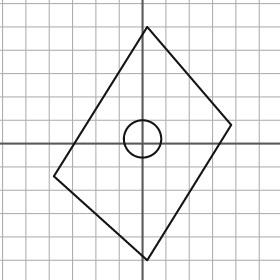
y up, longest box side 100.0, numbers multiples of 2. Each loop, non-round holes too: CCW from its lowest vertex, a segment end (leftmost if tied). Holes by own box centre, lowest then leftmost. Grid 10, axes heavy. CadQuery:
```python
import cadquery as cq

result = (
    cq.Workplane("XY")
    .moveTo(2.0, -50.0)
    .lineTo(38.0, 8.0)
    .lineTo(2.0, 50.0)
    .lineTo(-38.0, -14.0)
    .close()
    .moveTo(0.0, 2.0)
    .circle(8.0)
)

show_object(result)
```